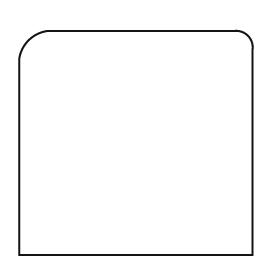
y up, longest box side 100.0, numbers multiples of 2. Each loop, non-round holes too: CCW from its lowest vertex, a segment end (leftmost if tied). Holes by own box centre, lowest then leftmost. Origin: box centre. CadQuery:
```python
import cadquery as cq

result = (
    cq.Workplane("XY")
    .moveTo(-50.0, -48.0)
    .lineTo(50.0, -48.0)
    .lineTo(50.0, 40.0)
    .threePointArc((48.0, 46.0), (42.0, 48.0))
    .lineTo(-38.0, 48.0)
    .threePointArc((-46.0, 44.0), (-50.0, 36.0))
    .close()
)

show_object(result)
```